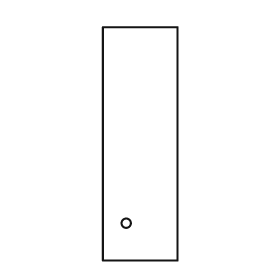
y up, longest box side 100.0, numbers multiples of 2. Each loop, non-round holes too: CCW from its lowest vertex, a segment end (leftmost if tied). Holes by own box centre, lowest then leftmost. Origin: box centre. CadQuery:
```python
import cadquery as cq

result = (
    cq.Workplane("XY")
    .moveTo(-16.0, -50.0)
    .lineTo(16.0, -50.0)
    .lineTo(16.0, 50.0)
    .lineTo(-16.0, 50.0)
    .close()
    .moveTo(-6.0, -34.0)
    .circle(2.0)
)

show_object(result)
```